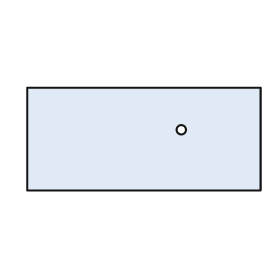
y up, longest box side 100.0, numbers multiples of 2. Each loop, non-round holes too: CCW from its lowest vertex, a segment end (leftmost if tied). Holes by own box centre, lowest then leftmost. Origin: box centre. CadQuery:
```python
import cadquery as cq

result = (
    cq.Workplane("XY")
    .moveTo(-50.0, -22.0)
    .lineTo(50.0, -22.0)
    .lineTo(50.0, 22.0)
    .lineTo(-50.0, 22.0)
    .close()
    .moveTo(16.0, 4.0)
    .circle(2.0)
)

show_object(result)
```